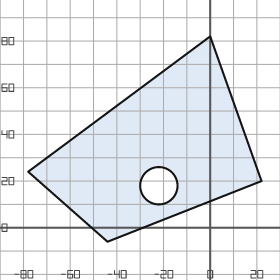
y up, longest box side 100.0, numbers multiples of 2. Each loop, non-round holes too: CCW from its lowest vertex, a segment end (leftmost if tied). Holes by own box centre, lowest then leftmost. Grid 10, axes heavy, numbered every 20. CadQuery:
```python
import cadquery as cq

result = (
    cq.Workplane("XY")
    .moveTo(-44.0, -6.0)
    .lineTo(22.0, 20.0)
    .lineTo(0.0, 82.0)
    .lineTo(-78.0, 24.0)
    .close()
    .moveTo(-22.0, 18.0)
    .circle(8.0)
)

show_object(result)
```